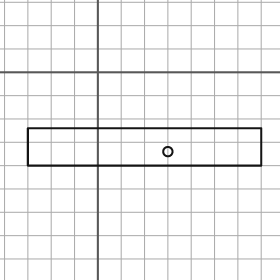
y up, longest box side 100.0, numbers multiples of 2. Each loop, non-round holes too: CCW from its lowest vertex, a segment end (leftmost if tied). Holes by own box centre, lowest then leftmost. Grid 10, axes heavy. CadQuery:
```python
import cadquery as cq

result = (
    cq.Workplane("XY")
    .moveTo(-30.0, -40.0)
    .lineTo(70.0, -40.0)
    .lineTo(70.0, -24.0)
    .lineTo(-30.0, -24.0)
    .close()
    .moveTo(30.0, -34.0)
    .circle(2.0)
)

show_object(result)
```